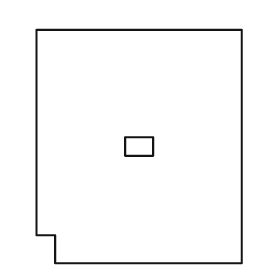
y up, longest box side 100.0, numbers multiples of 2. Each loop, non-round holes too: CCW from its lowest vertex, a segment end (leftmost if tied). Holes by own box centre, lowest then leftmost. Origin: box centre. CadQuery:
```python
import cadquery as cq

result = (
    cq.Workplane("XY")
    .moveTo(-36.0, -50.0)
    .lineTo(44.0, -50.0)
    .lineTo(44.0, 50.0)
    .lineTo(-44.0, 50.0)
    .lineTo(-44.0, -38.0)
    .lineTo(-36.0, -38.0)
    .close()
    .moveTo(-6.0, -4.0)
    .lineTo(6.0, -4.0)
    .lineTo(6.0, 4.0)
    .lineTo(-6.0, 4.0)
    .close()
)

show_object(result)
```